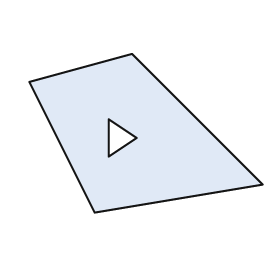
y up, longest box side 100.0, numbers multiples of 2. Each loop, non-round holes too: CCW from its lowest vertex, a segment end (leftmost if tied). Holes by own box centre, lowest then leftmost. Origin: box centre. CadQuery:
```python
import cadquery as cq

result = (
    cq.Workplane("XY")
    .moveTo(-22.0, -34.0)
    .lineTo(50.0, -22.0)
    .lineTo(-6.0, 34.0)
    .lineTo(-50.0, 22.0)
    .close()
    .moveTo(-16.0, -10.0)
    .lineTo(-4.0, -2.0)
    .lineTo(-16.0, 6.0)
    .close()
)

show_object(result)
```